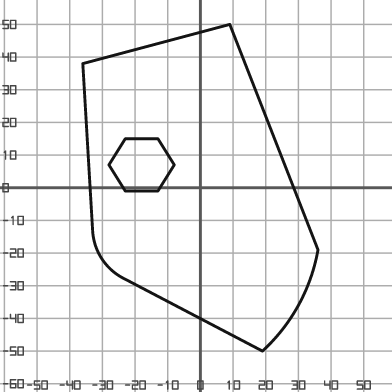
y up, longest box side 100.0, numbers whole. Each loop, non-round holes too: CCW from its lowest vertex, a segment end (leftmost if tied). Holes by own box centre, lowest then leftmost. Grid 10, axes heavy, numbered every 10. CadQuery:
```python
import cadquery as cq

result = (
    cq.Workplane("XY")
    .moveTo(19.0, -50.0)
    .threePointArc((30.0, -36.0), (36.0, -19.0))
    .lineTo(9.0, 50.0)
    .lineTo(-36.0, 38.0)
    .lineTo(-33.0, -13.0)
    .threePointArc((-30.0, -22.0), (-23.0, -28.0))
    .close()
    .moveTo(-23.0, -1.0)
    .lineTo(-13.0, -1.0)
    .lineTo(-8.0, 7.0)
    .lineTo(-13.0, 15.0)
    .lineTo(-23.0, 15.0)
    .lineTo(-28.0, 7.0)
    .close()
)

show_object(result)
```